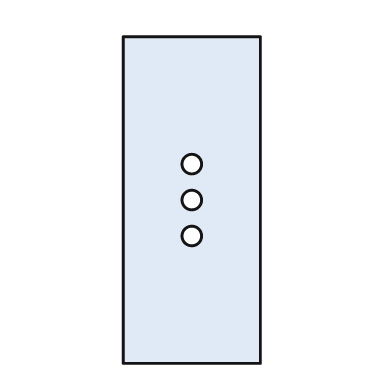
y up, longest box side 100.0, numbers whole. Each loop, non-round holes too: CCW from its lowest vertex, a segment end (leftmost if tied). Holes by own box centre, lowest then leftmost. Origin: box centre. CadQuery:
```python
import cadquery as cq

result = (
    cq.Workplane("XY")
    .moveTo(-21.0, -50.0)
    .lineTo(21.0, -50.0)
    .lineTo(21.0, 50.0)
    .lineTo(-21.0, 50.0)
    .close()
    .moveTo(0.0, -11.0)
    .circle(3.0)
    .moveTo(0.0, 0.0)
    .circle(3.0)
    .moveTo(0.0, 11.0)
    .circle(3.0)
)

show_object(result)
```